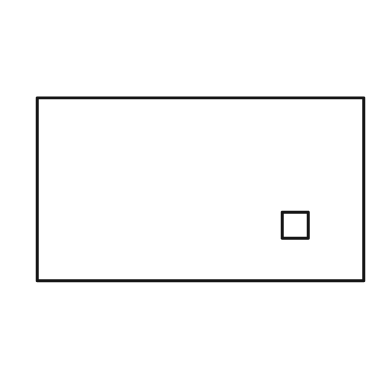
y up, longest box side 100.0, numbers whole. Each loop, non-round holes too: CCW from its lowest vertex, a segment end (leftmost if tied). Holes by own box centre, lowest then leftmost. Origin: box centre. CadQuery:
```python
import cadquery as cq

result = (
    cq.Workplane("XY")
    .moveTo(-50.0, -28.0)
    .lineTo(50.0, -28.0)
    .lineTo(50.0, 28.0)
    .lineTo(-50.0, 28.0)
    .close()
    .moveTo(25.0, -15.0)
    .lineTo(33.0, -15.0)
    .lineTo(33.0, -7.0)
    .lineTo(25.0, -7.0)
    .close()
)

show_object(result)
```